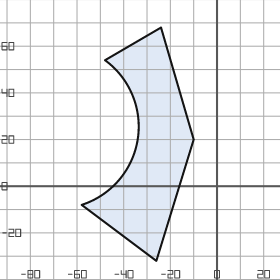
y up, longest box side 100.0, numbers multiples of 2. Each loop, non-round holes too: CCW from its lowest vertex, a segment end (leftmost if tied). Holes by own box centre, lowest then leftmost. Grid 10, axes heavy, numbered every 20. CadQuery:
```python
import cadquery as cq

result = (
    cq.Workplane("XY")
    .moveTo(-26.0, -32.0)
    .lineTo(-10.0, 20.0)
    .lineTo(-24.0, 68.0)
    .lineTo(-48.0, 54.0)
    .threePointArc((-34.0, 20.0), (-58.0, -8.0))
    .close()
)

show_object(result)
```